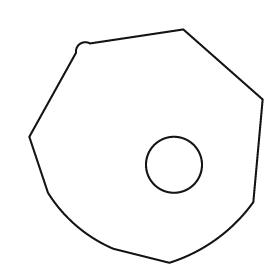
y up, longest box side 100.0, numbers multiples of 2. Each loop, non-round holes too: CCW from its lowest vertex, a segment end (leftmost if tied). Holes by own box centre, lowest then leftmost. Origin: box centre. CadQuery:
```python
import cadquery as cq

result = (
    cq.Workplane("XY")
    .moveTo(10.0, -50.0)
    .threePointArc((30.0, -40.0), (46.0, -24.0))
    .lineTo(50.0, 20.0)
    .lineTo(16.0, 50.0)
    .lineTo(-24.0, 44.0)
    .threePointArc((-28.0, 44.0), (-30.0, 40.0))
    .lineTo(-50.0, 4.0)
    .lineTo(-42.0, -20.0)
    .threePointArc((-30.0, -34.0), (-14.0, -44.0))
    .close()
    .moveTo(12.0, -8.0)
    .circle(12.0)
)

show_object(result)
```